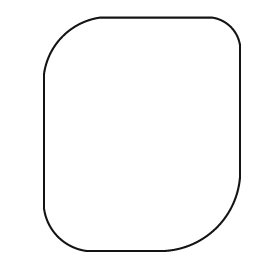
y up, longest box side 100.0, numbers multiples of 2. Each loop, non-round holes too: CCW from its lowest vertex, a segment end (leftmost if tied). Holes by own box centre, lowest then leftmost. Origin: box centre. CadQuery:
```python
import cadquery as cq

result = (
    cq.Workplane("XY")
    .moveTo(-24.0, -50.0)
    .lineTo(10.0, -50.0)
    .threePointArc((32.0, -40.0), (42.0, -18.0))
    .lineTo(42.0, 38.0)
    .threePointArc((38.0, 46.0), (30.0, 50.0))
    .lineTo(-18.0, 50.0)
    .threePointArc((-34.0, 42.0), (-42.0, 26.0))
    .lineTo(-42.0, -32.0)
    .threePointArc((-36.0, -44.0), (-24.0, -50.0))
    .close()
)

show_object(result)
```